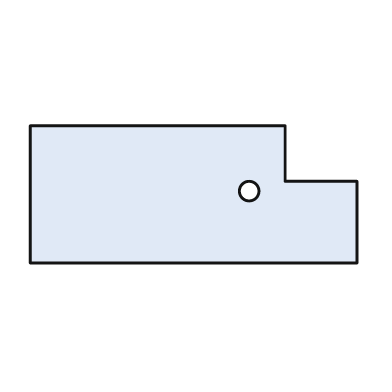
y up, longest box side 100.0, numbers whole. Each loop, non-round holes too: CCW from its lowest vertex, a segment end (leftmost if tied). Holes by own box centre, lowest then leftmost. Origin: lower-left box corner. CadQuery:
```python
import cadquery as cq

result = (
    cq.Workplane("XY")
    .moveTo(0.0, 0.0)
    .lineTo(100.0, 0.0)
    .lineTo(100.0, 25.0)
    .lineTo(78.0, 25.0)
    .lineTo(78.0, 42.0)
    .lineTo(0.0, 42.0)
    .close()
    .moveTo(67.0, 22.0)
    .circle(3.0)
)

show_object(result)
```